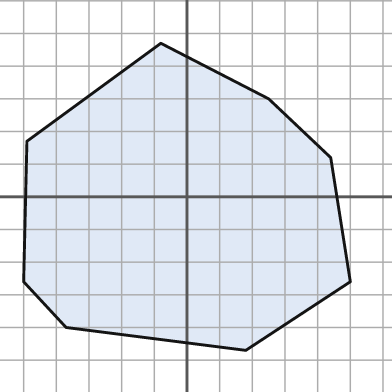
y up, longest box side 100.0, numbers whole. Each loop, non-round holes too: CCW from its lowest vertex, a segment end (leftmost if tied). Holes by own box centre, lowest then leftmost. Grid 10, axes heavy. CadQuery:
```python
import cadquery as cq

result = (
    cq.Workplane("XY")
    .moveTo(18.0, -47.0)
    .lineTo(50.0, -26.0)
    .lineTo(44.0, 12.0)
    .lineTo(25.0, 30.0)
    .lineTo(-8.0, 47.0)
    .lineTo(-49.0, 17.0)
    .lineTo(-50.0, -26.0)
    .lineTo(-37.0, -40.0)
    .close()
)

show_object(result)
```